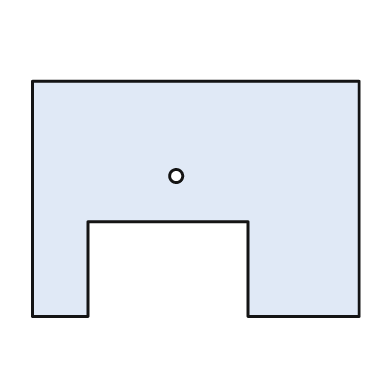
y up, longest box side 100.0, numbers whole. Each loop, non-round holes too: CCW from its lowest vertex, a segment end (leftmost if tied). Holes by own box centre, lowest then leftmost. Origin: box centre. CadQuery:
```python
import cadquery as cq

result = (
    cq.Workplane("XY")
    .moveTo(-50.0, -36.0)
    .lineTo(-33.0, -36.0)
    .lineTo(-33.0, -7.0)
    .lineTo(16.0, -7.0)
    .lineTo(16.0, -36.0)
    .lineTo(50.0, -36.0)
    .lineTo(50.0, 36.0)
    .lineTo(-50.0, 36.0)
    .close()
    .moveTo(-6.0, 7.0)
    .circle(2.0)
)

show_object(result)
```